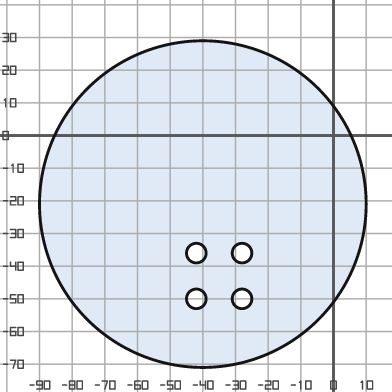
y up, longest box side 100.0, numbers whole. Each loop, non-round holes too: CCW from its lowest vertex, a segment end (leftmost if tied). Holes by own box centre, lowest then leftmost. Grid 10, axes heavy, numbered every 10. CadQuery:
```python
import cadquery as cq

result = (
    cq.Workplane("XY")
    .moveTo(-40.0, -21.0)
    .circle(50.0)
    .moveTo(-42.0, -50.0)
    .circle(3.0)
    .moveTo(-28.0, -50.0)
    .circle(3.0)
    .moveTo(-42.0, -36.0)
    .circle(3.0)
    .moveTo(-28.0, -36.0)
    .circle(3.0)
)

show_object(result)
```